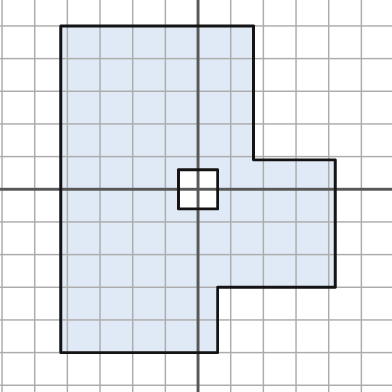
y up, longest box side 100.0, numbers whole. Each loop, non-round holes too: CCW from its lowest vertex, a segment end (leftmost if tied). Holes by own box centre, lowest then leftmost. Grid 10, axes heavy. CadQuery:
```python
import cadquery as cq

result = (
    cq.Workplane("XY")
    .moveTo(-42.0, -50.0)
    .lineTo(6.0, -50.0)
    .lineTo(6.0, -30.0)
    .lineTo(42.0, -30.0)
    .lineTo(42.0, 9.0)
    .lineTo(17.0, 9.0)
    .lineTo(17.0, 50.0)
    .lineTo(-42.0, 50.0)
    .close()
    .moveTo(-6.0, -6.0)
    .lineTo(6.0, -6.0)
    .lineTo(6.0, 6.0)
    .lineTo(-6.0, 6.0)
    .close()
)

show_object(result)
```